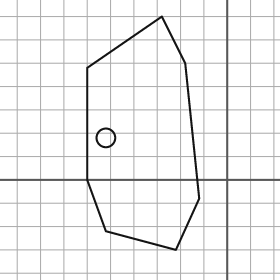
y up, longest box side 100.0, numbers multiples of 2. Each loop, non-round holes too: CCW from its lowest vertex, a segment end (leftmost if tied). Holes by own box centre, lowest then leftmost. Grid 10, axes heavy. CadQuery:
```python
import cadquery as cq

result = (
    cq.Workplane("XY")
    .moveTo(-22.0, -30.0)
    .lineTo(-12.0, -8.0)
    .lineTo(-18.0, 50.0)
    .lineTo(-28.0, 70.0)
    .lineTo(-60.0, 48.0)
    .lineTo(-60.0, 0.0)
    .lineTo(-52.0, -22.0)
    .close()
    .moveTo(-52.0, 18.0)
    .circle(4.0)
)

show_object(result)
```